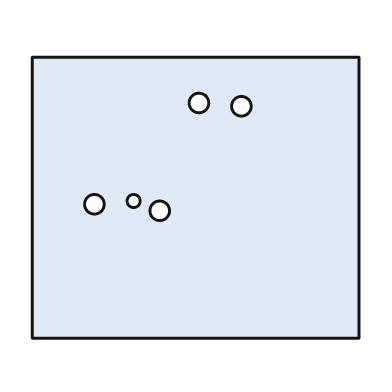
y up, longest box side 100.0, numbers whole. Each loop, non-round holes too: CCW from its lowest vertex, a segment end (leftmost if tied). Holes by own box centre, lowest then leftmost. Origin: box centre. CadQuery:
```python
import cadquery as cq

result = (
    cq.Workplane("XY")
    .moveTo(-50.0, -43.0)
    .lineTo(50.0, -43.0)
    .lineTo(50.0, 43.0)
    .lineTo(-50.0, 43.0)
    .close()
    .moveTo(-11.0, -4.0)
    .circle(3.0)
    .moveTo(-31.0, -2.0)
    .circle(3.0)
    .moveTo(-19.0, -1.0)
    .circle(2.0)
    .moveTo(14.0, 28.0)
    .circle(3.0)
    .moveTo(1.0, 29.0)
    .circle(3.0)
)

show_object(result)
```